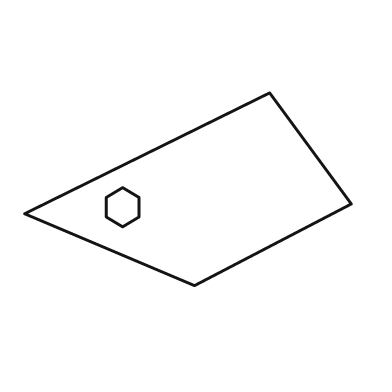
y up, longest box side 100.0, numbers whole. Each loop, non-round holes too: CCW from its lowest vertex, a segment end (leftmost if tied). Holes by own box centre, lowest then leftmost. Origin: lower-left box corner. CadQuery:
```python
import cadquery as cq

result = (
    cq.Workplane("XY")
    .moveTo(52.0, 0.0)
    .lineTo(100.0, 25.0)
    .lineTo(75.0, 59.0)
    .lineTo(0.0, 22.0)
    .close()
    .moveTo(30.0, 18.0)
    .lineTo(35.0, 21.0)
    .lineTo(35.0, 27.0)
    .lineTo(30.0, 30.0)
    .lineTo(25.0, 27.0)
    .lineTo(25.0, 21.0)
    .close()
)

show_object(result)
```